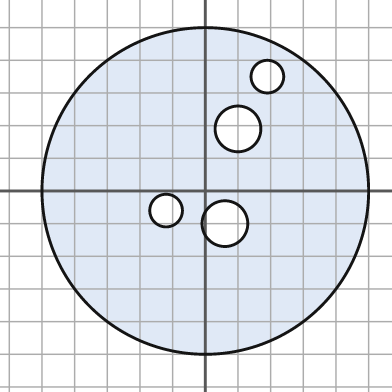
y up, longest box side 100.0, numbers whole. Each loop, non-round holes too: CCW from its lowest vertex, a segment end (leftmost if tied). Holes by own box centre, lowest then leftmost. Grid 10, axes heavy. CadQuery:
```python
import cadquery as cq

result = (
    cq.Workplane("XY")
    .moveTo(0.0, 0.0)
    .circle(50.0)
    .moveTo(6.0, -10.0)
    .circle(7.0)
    .moveTo(-12.0, -6.0)
    .circle(5.0)
    .moveTo(10.0, 19.0)
    .circle(7.0)
    .moveTo(19.0, 35.0)
    .circle(5.0)
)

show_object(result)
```